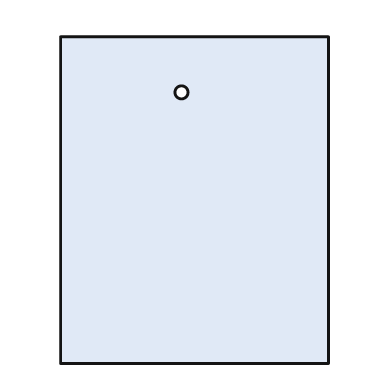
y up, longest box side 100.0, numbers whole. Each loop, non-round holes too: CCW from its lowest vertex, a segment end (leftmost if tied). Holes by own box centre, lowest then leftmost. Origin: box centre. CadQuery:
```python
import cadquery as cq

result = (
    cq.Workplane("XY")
    .moveTo(-41.0, -50.0)
    .lineTo(41.0, -50.0)
    .lineTo(41.0, 50.0)
    .lineTo(-41.0, 50.0)
    .close()
    .moveTo(-4.0, 33.0)
    .circle(2.0)
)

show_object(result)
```